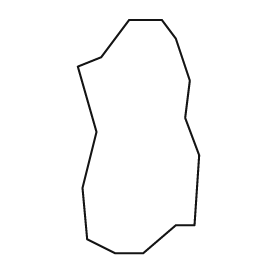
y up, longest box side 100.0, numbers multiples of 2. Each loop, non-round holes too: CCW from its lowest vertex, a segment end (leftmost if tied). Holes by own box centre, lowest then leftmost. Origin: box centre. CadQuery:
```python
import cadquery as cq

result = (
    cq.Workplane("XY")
    .moveTo(-10.0, -50.0)
    .lineTo(2.0, -50.0)
    .lineTo(16.0, -38.0)
    .lineTo(24.0, -38.0)
    .lineTo(26.0, -8.0)
    .lineTo(20.0, 8.0)
    .lineTo(22.0, 24.0)
    .lineTo(16.0, 42.0)
    .lineTo(10.0, 50.0)
    .lineTo(-4.0, 50.0)
    .lineTo(-16.0, 34.0)
    .lineTo(-26.0, 30.0)
    .lineTo(-18.0, 2.0)
    .lineTo(-24.0, -22.0)
    .lineTo(-22.0, -44.0)
    .close()
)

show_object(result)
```